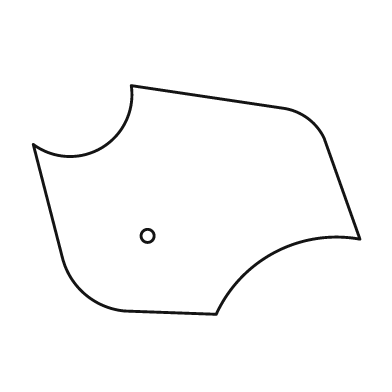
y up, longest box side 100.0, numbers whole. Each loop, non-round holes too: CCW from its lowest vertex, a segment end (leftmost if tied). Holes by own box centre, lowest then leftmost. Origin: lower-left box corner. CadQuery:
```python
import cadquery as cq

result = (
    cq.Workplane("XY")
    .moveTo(56.0, 0.0)
    .threePointArc((74.0, 19.0), (100.0, 23.0))
    .lineTo(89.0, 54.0)
    .threePointArc((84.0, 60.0), (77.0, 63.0))
    .lineTo(30.0, 70.0)
    .threePointArc((21.0, 51.0), (0.0, 52.0))
    .lineTo(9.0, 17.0)
    .threePointArc((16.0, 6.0), (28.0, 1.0))
    .close()
    .moveTo(35.0, 24.0)
    .circle(2.0)
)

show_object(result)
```